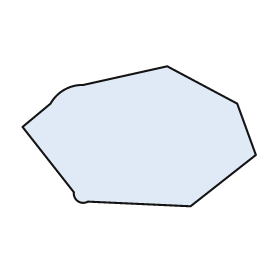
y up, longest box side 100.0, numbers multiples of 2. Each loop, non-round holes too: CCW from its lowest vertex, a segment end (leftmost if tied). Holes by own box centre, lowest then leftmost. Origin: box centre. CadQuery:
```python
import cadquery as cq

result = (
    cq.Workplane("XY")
    .moveTo(22.0, -30.0)
    .lineTo(50.0, -8.0)
    .lineTo(42.0, 14.0)
    .lineTo(12.0, 30.0)
    .lineTo(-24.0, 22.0)
    .threePointArc((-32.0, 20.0), (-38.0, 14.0))
    .lineTo(-50.0, 4.0)
    .lineTo(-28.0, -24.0)
    .threePointArc((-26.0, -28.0), (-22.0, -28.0))
    .close()
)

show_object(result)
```